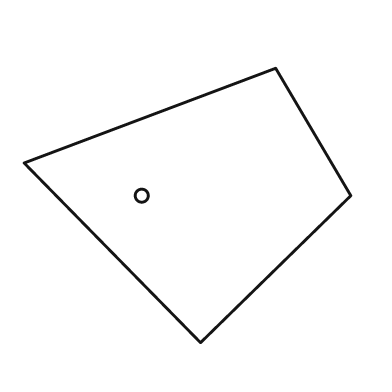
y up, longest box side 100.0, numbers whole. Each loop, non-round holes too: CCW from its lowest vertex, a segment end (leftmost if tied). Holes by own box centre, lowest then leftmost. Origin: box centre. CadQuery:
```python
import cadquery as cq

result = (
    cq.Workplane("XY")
    .moveTo(4.0, -42.0)
    .lineTo(50.0, 3.0)
    .lineTo(27.0, 42.0)
    .lineTo(-50.0, 13.0)
    .close()
    .moveTo(-14.0, 3.0)
    .circle(2.0)
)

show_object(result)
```